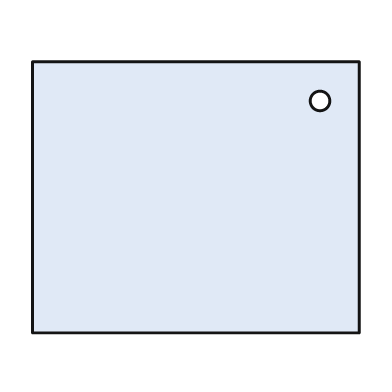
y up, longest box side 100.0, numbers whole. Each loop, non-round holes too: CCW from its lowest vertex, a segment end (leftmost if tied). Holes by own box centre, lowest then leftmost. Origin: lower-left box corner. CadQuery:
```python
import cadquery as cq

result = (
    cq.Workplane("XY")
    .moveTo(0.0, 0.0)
    .lineTo(100.0, 0.0)
    .lineTo(100.0, 83.0)
    .lineTo(0.0, 83.0)
    .close()
    .moveTo(88.0, 71.0)
    .circle(3.0)
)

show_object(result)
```